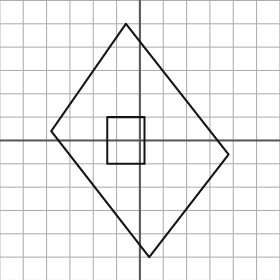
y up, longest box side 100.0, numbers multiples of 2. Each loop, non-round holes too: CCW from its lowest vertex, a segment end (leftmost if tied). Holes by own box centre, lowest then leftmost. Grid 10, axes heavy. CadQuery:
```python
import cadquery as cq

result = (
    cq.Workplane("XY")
    .moveTo(4.0, -50.0)
    .lineTo(38.0, -6.0)
    .lineTo(-6.0, 50.0)
    .lineTo(-38.0, 4.0)
    .close()
    .moveTo(-14.0, -10.0)
    .lineTo(2.0, -10.0)
    .lineTo(2.0, 10.0)
    .lineTo(-14.0, 10.0)
    .close()
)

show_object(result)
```